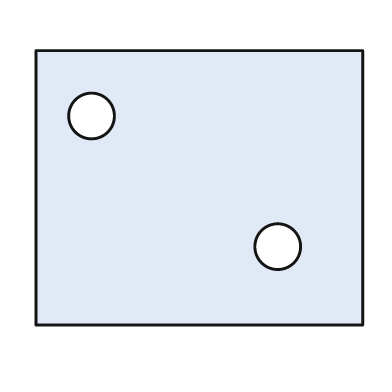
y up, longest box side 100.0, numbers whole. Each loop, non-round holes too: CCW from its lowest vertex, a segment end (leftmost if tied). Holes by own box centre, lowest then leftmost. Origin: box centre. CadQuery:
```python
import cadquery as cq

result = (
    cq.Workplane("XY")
    .moveTo(-50.0, -42.0)
    .lineTo(50.0, -42.0)
    .lineTo(50.0, 42.0)
    .lineTo(-50.0, 42.0)
    .close()
    .moveTo(24.0, -18.0)
    .circle(7.0)
    .moveTo(-33.0, 22.0)
    .circle(7.0)
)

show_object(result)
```